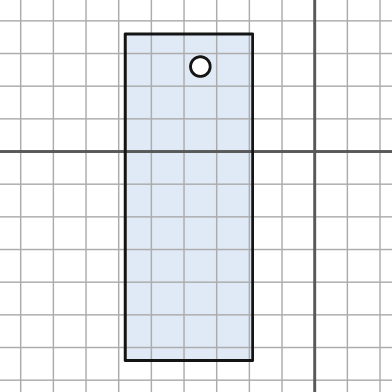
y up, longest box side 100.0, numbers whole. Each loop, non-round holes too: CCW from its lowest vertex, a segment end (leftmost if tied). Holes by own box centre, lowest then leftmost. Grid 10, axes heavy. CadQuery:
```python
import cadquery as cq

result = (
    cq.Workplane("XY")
    .moveTo(-58.0, -64.0)
    .lineTo(-19.0, -64.0)
    .lineTo(-19.0, 36.0)
    .lineTo(-58.0, 36.0)
    .close()
    .moveTo(-35.0, 26.0)
    .circle(3.0)
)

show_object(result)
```